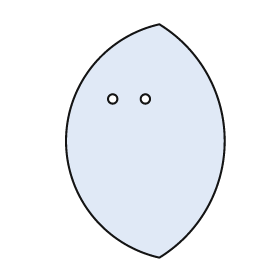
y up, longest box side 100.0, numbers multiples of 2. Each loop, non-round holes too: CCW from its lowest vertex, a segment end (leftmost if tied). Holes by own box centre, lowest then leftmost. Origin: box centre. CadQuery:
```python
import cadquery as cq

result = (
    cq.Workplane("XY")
    .moveTo(6.0, -50.0)
    .threePointArc((34.0, 0.0), (6.0, 50.0))
    .threePointArc((-34.0, 0.0), (6.0, -50.0))
    .close()
    .moveTo(-14.0, 18.0)
    .circle(2.0)
    .moveTo(0.0, 18.0)
    .circle(2.0)
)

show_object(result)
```